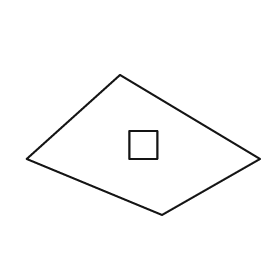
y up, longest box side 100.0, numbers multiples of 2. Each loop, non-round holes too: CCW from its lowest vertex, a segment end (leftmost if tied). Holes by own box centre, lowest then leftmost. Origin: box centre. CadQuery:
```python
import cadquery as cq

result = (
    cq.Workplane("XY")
    .moveTo(8.0, -30.0)
    .lineTo(50.0, -6.0)
    .lineTo(-10.0, 30.0)
    .lineTo(-50.0, -6.0)
    .close()
    .moveTo(-6.0, -6.0)
    .lineTo(6.0, -6.0)
    .lineTo(6.0, 6.0)
    .lineTo(-6.0, 6.0)
    .close()
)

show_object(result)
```